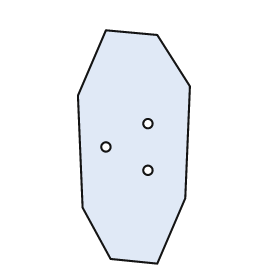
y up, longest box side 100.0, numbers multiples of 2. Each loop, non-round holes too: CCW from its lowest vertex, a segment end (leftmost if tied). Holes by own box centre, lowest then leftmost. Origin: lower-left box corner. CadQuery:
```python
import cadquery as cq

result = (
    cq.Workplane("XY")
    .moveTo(34.0, 0.0)
    .lineTo(46.0, 28.0)
    .lineTo(48.0, 76.0)
    .lineTo(34.0, 98.0)
    .lineTo(12.0, 100.0)
    .lineTo(0.0, 72.0)
    .lineTo(2.0, 24.0)
    .lineTo(14.0, 2.0)
    .close()
    .moveTo(30.0, 40.0)
    .circle(2.0)
    .moveTo(12.0, 50.0)
    .circle(2.0)
    .moveTo(30.0, 60.0)
    .circle(2.0)
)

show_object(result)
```